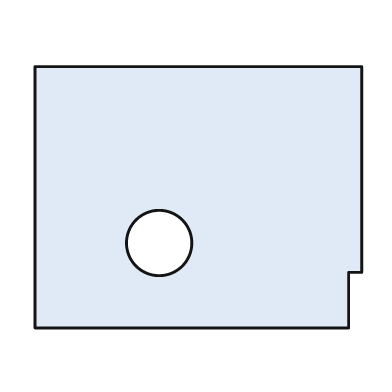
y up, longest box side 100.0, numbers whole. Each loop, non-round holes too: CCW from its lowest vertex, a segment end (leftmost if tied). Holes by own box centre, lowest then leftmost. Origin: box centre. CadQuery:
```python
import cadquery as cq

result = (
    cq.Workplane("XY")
    .moveTo(-50.0, -40.0)
    .lineTo(46.0, -40.0)
    .lineTo(46.0, -23.0)
    .lineTo(50.0, -23.0)
    .lineTo(50.0, 40.0)
    .lineTo(-50.0, 40.0)
    .close()
    .moveTo(-12.0, -14.0)
    .circle(10.0)
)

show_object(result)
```